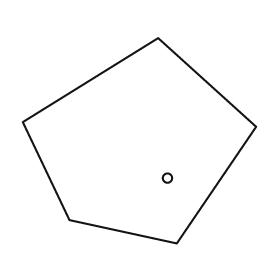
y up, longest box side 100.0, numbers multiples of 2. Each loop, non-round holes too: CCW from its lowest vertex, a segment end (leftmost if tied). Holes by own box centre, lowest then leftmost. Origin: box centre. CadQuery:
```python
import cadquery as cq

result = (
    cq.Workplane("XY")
    .moveTo(16.0, -44.0)
    .lineTo(50.0, 6.0)
    .lineTo(8.0, 44.0)
    .lineTo(-50.0, 8.0)
    .lineTo(-30.0, -34.0)
    .close()
    .moveTo(12.0, -16.0)
    .circle(2.0)
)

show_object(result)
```